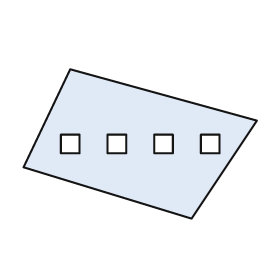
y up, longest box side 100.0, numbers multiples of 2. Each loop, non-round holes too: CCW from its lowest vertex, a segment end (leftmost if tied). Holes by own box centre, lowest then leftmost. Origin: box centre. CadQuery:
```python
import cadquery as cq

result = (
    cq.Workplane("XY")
    .moveTo(22.0, -32.0)
    .lineTo(50.0, 10.0)
    .lineTo(-30.0, 32.0)
    .lineTo(-50.0, -10.0)
    .close()
    .moveTo(-34.0, -4.0)
    .lineTo(-26.0, -4.0)
    .lineTo(-26.0, 4.0)
    .lineTo(-34.0, 4.0)
    .close()
    .moveTo(-14.0, -4.0)
    .lineTo(-6.0, -4.0)
    .lineTo(-6.0, 4.0)
    .lineTo(-14.0, 4.0)
    .close()
    .moveTo(6.0, -4.0)
    .lineTo(14.0, -4.0)
    .lineTo(14.0, 4.0)
    .lineTo(6.0, 4.0)
    .close()
    .moveTo(26.0, -4.0)
    .lineTo(34.0, -4.0)
    .lineTo(34.0, 4.0)
    .lineTo(26.0, 4.0)
    .close()
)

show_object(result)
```